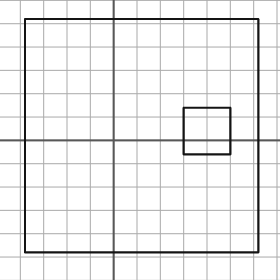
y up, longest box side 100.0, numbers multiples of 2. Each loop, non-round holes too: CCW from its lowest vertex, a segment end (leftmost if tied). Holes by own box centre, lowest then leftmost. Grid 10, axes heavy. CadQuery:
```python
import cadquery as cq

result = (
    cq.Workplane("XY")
    .moveTo(-38.0, -48.0)
    .lineTo(62.0, -48.0)
    .lineTo(62.0, 52.0)
    .lineTo(-38.0, 52.0)
    .close()
    .moveTo(30.0, -6.0)
    .lineTo(50.0, -6.0)
    .lineTo(50.0, 14.0)
    .lineTo(30.0, 14.0)
    .close()
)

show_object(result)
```